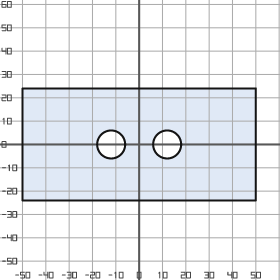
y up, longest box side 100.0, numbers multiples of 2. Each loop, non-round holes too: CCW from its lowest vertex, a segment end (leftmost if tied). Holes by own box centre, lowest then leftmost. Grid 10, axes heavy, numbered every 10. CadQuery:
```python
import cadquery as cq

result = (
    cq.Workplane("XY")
    .moveTo(-50.0, -24.0)
    .lineTo(50.0, -24.0)
    .lineTo(50.0, 24.0)
    .lineTo(-50.0, 24.0)
    .close()
    .moveTo(-12.0, 0.0)
    .circle(6.0)
    .moveTo(12.0, 0.0)
    .circle(6.0)
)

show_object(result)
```